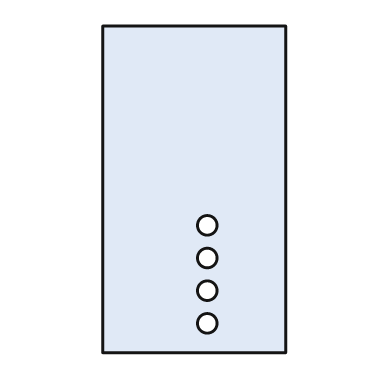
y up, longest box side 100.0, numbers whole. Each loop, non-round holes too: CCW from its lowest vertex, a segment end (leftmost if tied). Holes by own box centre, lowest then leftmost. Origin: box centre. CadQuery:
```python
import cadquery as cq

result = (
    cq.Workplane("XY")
    .moveTo(-28.0, -50.0)
    .lineTo(28.0, -50.0)
    .lineTo(28.0, 50.0)
    .lineTo(-28.0, 50.0)
    .close()
    .moveTo(4.0, -41.0)
    .circle(3.0)
    .moveTo(4.0, -31.0)
    .circle(3.0)
    .moveTo(4.0, -21.0)
    .circle(3.0)
    .moveTo(4.0, -11.0)
    .circle(3.0)
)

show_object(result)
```